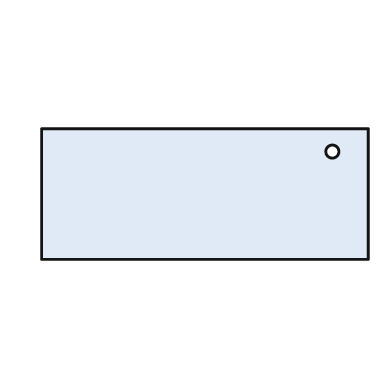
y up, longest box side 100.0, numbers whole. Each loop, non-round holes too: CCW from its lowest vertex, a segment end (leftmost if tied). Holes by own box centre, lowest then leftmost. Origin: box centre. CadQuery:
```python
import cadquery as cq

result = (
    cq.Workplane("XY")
    .moveTo(-50.0, -20.0)
    .lineTo(50.0, -20.0)
    .lineTo(50.0, 20.0)
    .lineTo(-50.0, 20.0)
    .close()
    .moveTo(39.0, 13.0)
    .circle(2.0)
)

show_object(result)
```